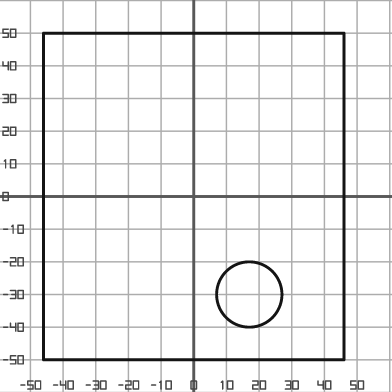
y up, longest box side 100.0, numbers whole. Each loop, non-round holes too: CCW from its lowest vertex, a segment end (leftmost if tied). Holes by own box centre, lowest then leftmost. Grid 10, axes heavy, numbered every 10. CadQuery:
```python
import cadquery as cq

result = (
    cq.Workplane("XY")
    .moveTo(-46.0, -50.0)
    .lineTo(46.0, -50.0)
    .lineTo(46.0, 50.0)
    .lineTo(-46.0, 50.0)
    .close()
    .moveTo(17.0, -30.0)
    .circle(10.0)
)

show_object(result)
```